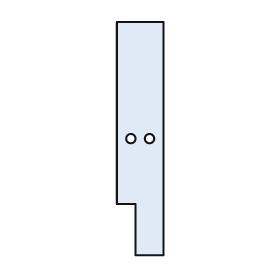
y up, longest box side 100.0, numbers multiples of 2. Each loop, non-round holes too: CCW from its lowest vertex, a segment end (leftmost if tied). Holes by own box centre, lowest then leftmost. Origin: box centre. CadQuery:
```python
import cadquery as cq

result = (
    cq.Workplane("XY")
    .moveTo(-2.0, -50.0)
    .lineTo(10.0, -50.0)
    .lineTo(10.0, 50.0)
    .lineTo(-10.0, 50.0)
    .lineTo(-10.0, -28.0)
    .lineTo(-2.0, -28.0)
    .close()
    .moveTo(-4.0, 0.0)
    .circle(2.0)
    .moveTo(4.0, 0.0)
    .circle(2.0)
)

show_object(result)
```